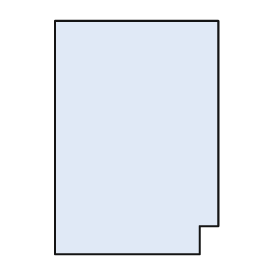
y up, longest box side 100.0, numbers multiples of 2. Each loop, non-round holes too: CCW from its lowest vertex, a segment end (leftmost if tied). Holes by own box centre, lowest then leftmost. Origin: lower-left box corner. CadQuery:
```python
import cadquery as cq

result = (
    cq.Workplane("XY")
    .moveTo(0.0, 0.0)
    .lineTo(62.0, 0.0)
    .lineTo(62.0, 12.0)
    .lineTo(70.0, 12.0)
    .lineTo(70.0, 100.0)
    .lineTo(0.0, 100.0)
    .close()
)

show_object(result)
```